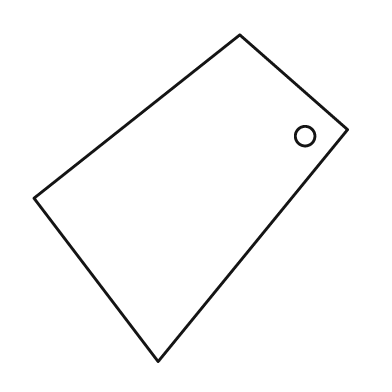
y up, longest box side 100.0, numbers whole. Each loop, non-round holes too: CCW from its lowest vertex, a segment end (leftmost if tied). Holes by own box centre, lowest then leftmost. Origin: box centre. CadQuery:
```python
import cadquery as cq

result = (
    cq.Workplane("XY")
    .moveTo(-10.0, -50.0)
    .lineTo(48.0, 21.0)
    .lineTo(15.0, 50.0)
    .lineTo(-48.0, 0.0)
    .close()
    .moveTo(35.0, 19.0)
    .circle(3.0)
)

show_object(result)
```